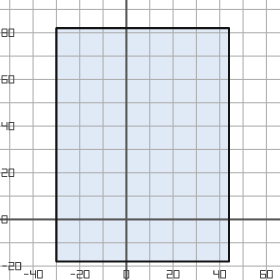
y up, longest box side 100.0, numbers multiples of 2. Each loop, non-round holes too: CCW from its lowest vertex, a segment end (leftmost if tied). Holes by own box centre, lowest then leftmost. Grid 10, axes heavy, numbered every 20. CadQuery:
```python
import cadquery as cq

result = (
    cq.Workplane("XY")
    .moveTo(-30.0, -18.0)
    .lineTo(44.0, -18.0)
    .lineTo(44.0, 82.0)
    .lineTo(-30.0, 82.0)
    .close()
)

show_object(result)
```